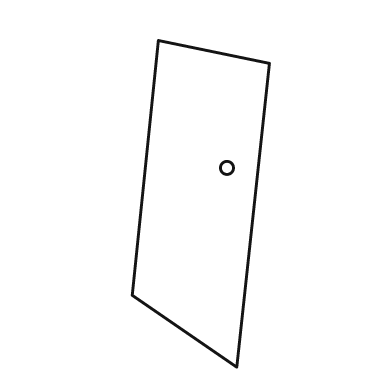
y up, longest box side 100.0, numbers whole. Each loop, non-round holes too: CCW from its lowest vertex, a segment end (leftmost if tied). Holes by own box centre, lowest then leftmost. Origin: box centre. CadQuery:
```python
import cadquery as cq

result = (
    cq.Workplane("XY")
    .moveTo(11.0, -50.0)
    .lineTo(21.0, 43.0)
    .lineTo(-13.0, 50.0)
    .lineTo(-21.0, -28.0)
    .close()
    .moveTo(8.0, 11.0)
    .circle(2.0)
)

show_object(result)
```